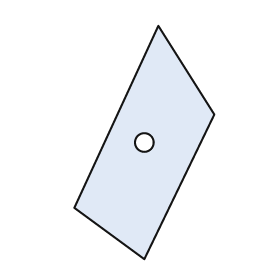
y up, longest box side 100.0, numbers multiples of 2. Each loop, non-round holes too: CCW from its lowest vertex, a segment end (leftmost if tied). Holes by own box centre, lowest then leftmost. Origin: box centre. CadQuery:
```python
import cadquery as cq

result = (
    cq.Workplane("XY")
    .moveTo(0.0, -50.0)
    .lineTo(30.0, 12.0)
    .lineTo(6.0, 50.0)
    .lineTo(-30.0, -28.0)
    .close()
    .moveTo(0.0, 0.0)
    .circle(4.0)
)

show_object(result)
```